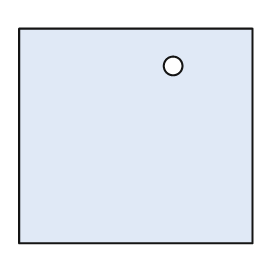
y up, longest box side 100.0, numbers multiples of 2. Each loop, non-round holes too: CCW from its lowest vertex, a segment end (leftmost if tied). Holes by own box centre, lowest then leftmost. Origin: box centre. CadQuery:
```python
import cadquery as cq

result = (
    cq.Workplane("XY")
    .moveTo(-50.0, -46.0)
    .lineTo(50.0, -46.0)
    .lineTo(50.0, 46.0)
    .lineTo(-50.0, 46.0)
    .close()
    .moveTo(16.0, 30.0)
    .circle(4.0)
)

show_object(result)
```